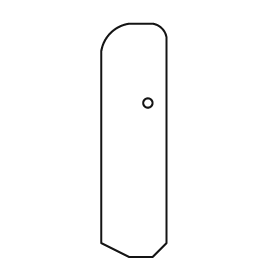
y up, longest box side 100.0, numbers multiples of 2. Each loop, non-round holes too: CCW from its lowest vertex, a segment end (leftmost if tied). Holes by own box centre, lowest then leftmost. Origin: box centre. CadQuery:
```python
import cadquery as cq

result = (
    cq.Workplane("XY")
    .moveTo(-2.0, -50.0)
    .lineTo(8.0, -50.0)
    .lineTo(14.0, -44.0)
    .lineTo(14.0, 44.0)
    .threePointArc((12.0, 48.0), (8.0, 50.0))
    .lineTo(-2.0, 50.0)
    .threePointArc((-10.0, 46.0), (-14.0, 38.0))
    .lineTo(-14.0, -44.0)
    .close()
    .moveTo(6.0, 16.0)
    .circle(2.0)
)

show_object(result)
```